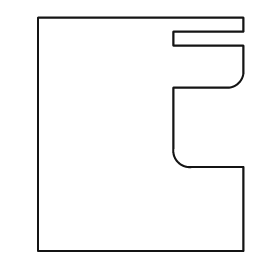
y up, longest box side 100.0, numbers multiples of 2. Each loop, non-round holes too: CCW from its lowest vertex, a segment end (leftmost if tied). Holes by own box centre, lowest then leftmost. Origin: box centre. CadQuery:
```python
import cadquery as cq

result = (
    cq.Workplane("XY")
    .moveTo(-44.0, -50.0)
    .lineTo(44.0, -50.0)
    .lineTo(44.0, -14.0)
    .lineTo(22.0, -14.0)
    .threePointArc((16.0, -12.0), (14.0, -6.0))
    .lineTo(14.0, 20.0)
    .lineTo(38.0, 20.0)
    .threePointArc((42.0, 22.0), (44.0, 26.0))
    .lineTo(44.0, 38.0)
    .lineTo(14.0, 38.0)
    .lineTo(14.0, 44.0)
    .lineTo(44.0, 44.0)
    .lineTo(44.0, 50.0)
    .lineTo(-44.0, 50.0)
    .close()
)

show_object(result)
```